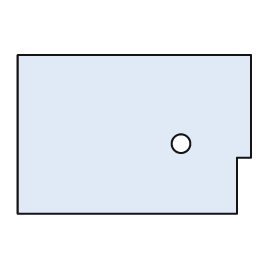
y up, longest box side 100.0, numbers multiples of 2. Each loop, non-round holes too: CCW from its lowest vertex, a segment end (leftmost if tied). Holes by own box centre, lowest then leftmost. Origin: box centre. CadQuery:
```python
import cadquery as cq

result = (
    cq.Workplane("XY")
    .moveTo(-50.0, -34.0)
    .lineTo(44.0, -34.0)
    .lineTo(44.0, -10.0)
    .lineTo(50.0, -10.0)
    .lineTo(50.0, 34.0)
    .lineTo(-50.0, 34.0)
    .close()
    .moveTo(20.0, -4.0)
    .circle(4.0)
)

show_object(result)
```